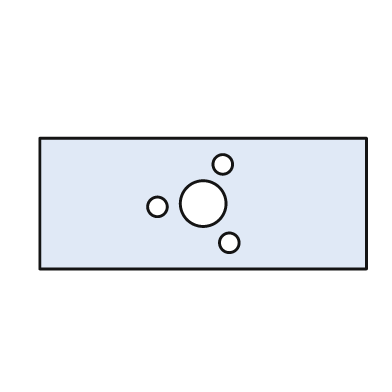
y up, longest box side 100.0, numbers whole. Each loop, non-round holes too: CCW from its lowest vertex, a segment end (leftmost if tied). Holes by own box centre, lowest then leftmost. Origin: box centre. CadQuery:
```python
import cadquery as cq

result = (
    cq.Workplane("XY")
    .moveTo(-50.0, -20.0)
    .lineTo(50.0, -20.0)
    .lineTo(50.0, 20.0)
    .lineTo(-50.0, 20.0)
    .close()
    .moveTo(8.0, -12.0)
    .circle(3.0)
    .moveTo(-14.0, -1.0)
    .circle(3.0)
    .moveTo(0.0, 0.0)
    .circle(7.0)
    .moveTo(6.0, 12.0)
    .circle(3.0)
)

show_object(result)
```